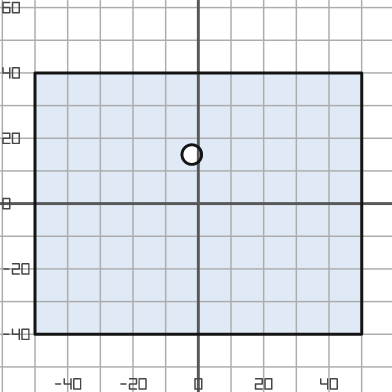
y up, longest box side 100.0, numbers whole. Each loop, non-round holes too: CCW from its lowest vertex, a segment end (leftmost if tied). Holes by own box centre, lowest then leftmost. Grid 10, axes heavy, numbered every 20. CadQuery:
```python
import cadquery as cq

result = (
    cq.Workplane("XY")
    .moveTo(-50.0, -40.0)
    .lineTo(50.0, -40.0)
    .lineTo(50.0, 40.0)
    .lineTo(-50.0, 40.0)
    .close()
    .moveTo(-2.0, 15.0)
    .circle(3.0)
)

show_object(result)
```